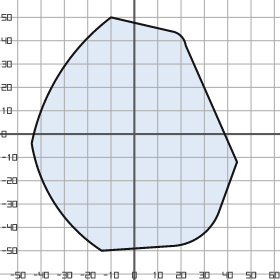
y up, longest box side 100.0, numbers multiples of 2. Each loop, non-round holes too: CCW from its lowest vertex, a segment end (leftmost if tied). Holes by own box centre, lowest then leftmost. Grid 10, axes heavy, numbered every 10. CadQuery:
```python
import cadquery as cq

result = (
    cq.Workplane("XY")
    .moveTo(-14.0, -50.0)
    .lineTo(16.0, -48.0)
    .threePointArc((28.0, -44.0), (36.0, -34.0))
    .lineTo(44.0, -12.0)
    .lineTo(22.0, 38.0)
    .threePointArc((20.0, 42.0), (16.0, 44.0))
    .lineTo(-10.0, 50.0)
    .threePointArc((-32.0, 26.0), (-44.0, -4.0))
    .threePointArc((-34.0, -30.0), (-14.0, -50.0))
    .close()
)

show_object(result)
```